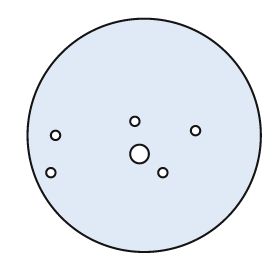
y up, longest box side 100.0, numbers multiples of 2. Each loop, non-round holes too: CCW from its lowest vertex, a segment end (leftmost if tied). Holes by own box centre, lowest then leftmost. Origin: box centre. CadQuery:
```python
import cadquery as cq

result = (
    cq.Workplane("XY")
    .moveTo(0.0, 0.0)
    .circle(50.0)
    .moveTo(-40.0, -16.0)
    .circle(2.0)
    .moveTo(8.0, -16.0)
    .circle(2.0)
    .moveTo(-2.0, -8.0)
    .circle(4.0)
    .moveTo(-38.0, 0.0)
    .circle(2.0)
    .moveTo(22.0, 2.0)
    .circle(2.0)
    .moveTo(-4.0, 6.0)
    .circle(2.0)
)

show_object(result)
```